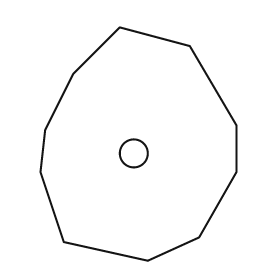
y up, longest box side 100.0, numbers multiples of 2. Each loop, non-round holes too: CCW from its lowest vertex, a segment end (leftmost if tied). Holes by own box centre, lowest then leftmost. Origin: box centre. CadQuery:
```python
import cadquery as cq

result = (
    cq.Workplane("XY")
    .moveTo(4.0, -50.0)
    .lineTo(26.0, -40.0)
    .lineTo(42.0, -12.0)
    .lineTo(42.0, 8.0)
    .lineTo(22.0, 42.0)
    .lineTo(-8.0, 50.0)
    .lineTo(-28.0, 30.0)
    .lineTo(-40.0, 6.0)
    .lineTo(-42.0, -12.0)
    .lineTo(-32.0, -42.0)
    .close()
    .moveTo(-2.0, -4.0)
    .circle(6.0)
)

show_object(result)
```